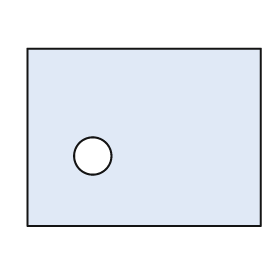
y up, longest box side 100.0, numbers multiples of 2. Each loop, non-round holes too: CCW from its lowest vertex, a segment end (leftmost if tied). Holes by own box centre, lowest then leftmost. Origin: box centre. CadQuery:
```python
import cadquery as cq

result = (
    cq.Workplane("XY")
    .moveTo(-50.0, -38.0)
    .lineTo(50.0, -38.0)
    .lineTo(50.0, 38.0)
    .lineTo(-50.0, 38.0)
    .close()
    .moveTo(-22.0, -8.0)
    .circle(8.0)
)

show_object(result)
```